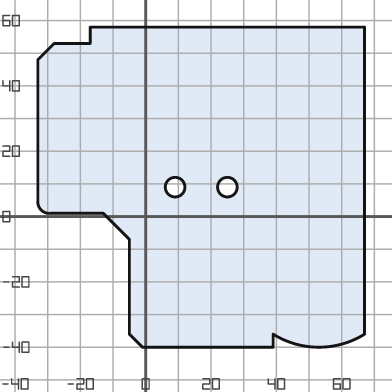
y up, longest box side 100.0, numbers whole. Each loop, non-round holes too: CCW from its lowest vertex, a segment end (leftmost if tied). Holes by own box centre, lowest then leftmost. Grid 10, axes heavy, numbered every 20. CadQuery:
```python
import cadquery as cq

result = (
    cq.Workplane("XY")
    .moveTo(-1.0, -40.0)
    .lineTo(39.0, -40.0)
    .lineTo(39.0, -36.0)
    .threePointArc((53.0, -40.0), (67.0, -36.0))
    .lineTo(67.0, 58.0)
    .lineTo(-17.0, 58.0)
    .lineTo(-17.0, 53.0)
    .lineTo(-28.0, 53.0)
    .lineTo(-33.0, 48.0)
    .lineTo(-33.0, 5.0)
    .threePointArc((-32.0, 2.0), (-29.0, 1.0))
    .lineTo(-13.0, 1.0)
    .lineTo(-5.0, -7.0)
    .lineTo(-5.0, -36.0)
    .close()
    .moveTo(9.0, 9.0)
    .circle(3.0)
    .moveTo(25.0, 9.0)
    .circle(3.0)
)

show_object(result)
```